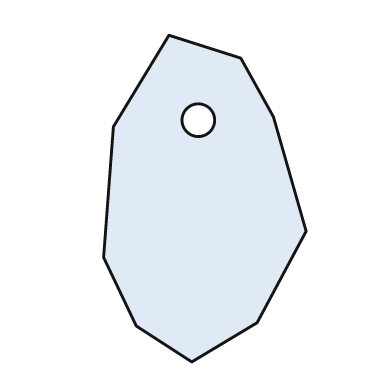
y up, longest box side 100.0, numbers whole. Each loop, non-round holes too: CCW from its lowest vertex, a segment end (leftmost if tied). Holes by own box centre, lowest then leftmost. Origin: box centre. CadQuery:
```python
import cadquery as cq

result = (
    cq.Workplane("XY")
    .moveTo(-4.0, -50.0)
    .lineTo(16.0, -38.0)
    .lineTo(31.0, -10.0)
    .lineTo(21.0, 25.0)
    .lineTo(11.0, 43.0)
    .lineTo(-11.0, 50.0)
    .lineTo(-28.0, 22.0)
    .lineTo(-31.0, -18.0)
    .lineTo(-21.0, -39.0)
    .close()
    .moveTo(-2.0, 24.0)
    .circle(5.0)
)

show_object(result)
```